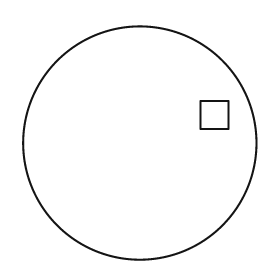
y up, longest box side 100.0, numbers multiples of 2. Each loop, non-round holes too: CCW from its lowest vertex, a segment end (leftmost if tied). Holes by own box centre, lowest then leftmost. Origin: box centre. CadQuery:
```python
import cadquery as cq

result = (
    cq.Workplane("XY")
    .moveTo(0.0, 0.0)
    .circle(50.0)
    .moveTo(26.0, 6.0)
    .lineTo(38.0, 6.0)
    .lineTo(38.0, 18.0)
    .lineTo(26.0, 18.0)
    .close()
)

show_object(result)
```